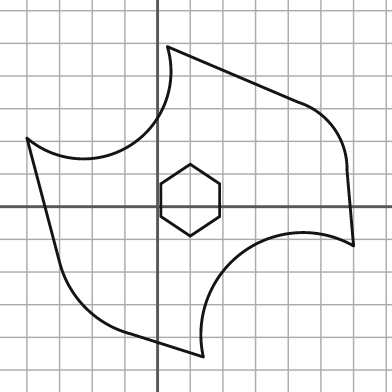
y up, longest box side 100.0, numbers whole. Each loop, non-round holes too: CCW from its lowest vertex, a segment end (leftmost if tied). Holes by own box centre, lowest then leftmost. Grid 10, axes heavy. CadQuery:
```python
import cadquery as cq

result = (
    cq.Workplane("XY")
    .moveTo(14.0, -46.0)
    .threePointArc((26.0, -14.0), (60.0, -12.0))
    .lineTo(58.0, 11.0)
    .threePointArc((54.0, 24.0), (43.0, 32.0))
    .lineTo(3.0, 49.0)
    .threePointArc((-8.0, 19.0), (-40.0, 21.0))
    .lineTo(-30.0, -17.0)
    .threePointArc((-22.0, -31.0), (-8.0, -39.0))
    .close()
    .moveTo(10.0, -9.0)
    .lineTo(19.0, -3.0)
    .lineTo(19.0, 7.0)
    .lineTo(10.0, 13.0)
    .lineTo(1.0, 7.0)
    .lineTo(1.0, -3.0)
    .close()
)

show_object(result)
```